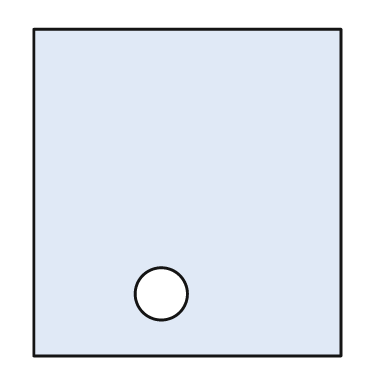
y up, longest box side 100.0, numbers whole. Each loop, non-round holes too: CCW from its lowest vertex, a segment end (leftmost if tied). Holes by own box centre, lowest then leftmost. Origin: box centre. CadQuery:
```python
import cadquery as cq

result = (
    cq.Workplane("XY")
    .moveTo(-47.0, -50.0)
    .lineTo(47.0, -50.0)
    .lineTo(47.0, 50.0)
    .lineTo(-47.0, 50.0)
    .close()
    .moveTo(-8.0, -31.0)
    .circle(8.0)
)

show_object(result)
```